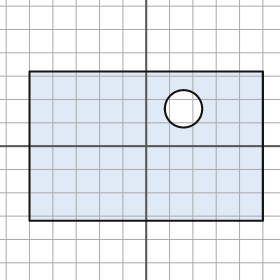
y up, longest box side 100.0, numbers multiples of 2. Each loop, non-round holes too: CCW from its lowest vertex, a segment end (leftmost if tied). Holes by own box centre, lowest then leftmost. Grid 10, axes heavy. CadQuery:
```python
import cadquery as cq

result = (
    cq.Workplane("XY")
    .moveTo(-50.0, -32.0)
    .lineTo(50.0, -32.0)
    .lineTo(50.0, 32.0)
    .lineTo(-50.0, 32.0)
    .close()
    .moveTo(16.0, 16.0)
    .circle(8.0)
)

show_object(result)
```